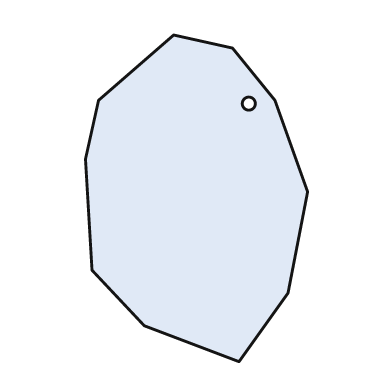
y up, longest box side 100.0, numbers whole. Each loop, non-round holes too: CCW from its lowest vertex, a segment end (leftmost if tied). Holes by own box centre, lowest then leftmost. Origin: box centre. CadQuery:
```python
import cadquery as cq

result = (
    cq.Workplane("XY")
    .moveTo(13.0, -50.0)
    .lineTo(28.0, -29.0)
    .lineTo(34.0, 2.0)
    .lineTo(24.0, 30.0)
    .lineTo(11.0, 46.0)
    .lineTo(-7.0, 50.0)
    .lineTo(-30.0, 30.0)
    .lineTo(-34.0, 12.0)
    .lineTo(-32.0, -22.0)
    .lineTo(-16.0, -39.0)
    .close()
    .moveTo(16.0, 29.0)
    .circle(2.0)
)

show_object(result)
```